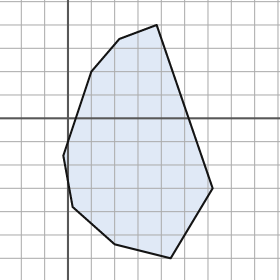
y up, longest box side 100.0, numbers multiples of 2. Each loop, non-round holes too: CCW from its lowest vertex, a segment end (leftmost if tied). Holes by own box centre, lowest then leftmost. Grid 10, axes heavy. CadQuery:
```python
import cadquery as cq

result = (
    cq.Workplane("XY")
    .moveTo(44.0, -60.0)
    .lineTo(62.0, -30.0)
    .lineTo(38.0, 40.0)
    .lineTo(22.0, 34.0)
    .lineTo(10.0, 20.0)
    .lineTo(-2.0, -16.0)
    .lineTo(2.0, -38.0)
    .lineTo(20.0, -54.0)
    .close()
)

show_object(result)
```